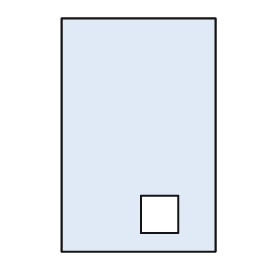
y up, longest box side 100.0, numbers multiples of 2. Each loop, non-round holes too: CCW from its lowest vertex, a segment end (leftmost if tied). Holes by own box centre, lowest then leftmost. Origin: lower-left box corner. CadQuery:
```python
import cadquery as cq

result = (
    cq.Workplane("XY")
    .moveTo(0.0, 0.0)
    .lineTo(66.0, 0.0)
    .lineTo(66.0, 100.0)
    .lineTo(0.0, 100.0)
    .close()
    .moveTo(34.0, 8.0)
    .lineTo(50.0, 8.0)
    .lineTo(50.0, 24.0)
    .lineTo(34.0, 24.0)
    .close()
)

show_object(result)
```